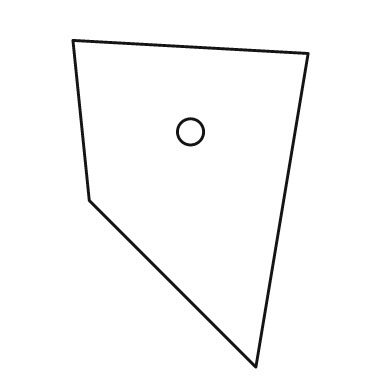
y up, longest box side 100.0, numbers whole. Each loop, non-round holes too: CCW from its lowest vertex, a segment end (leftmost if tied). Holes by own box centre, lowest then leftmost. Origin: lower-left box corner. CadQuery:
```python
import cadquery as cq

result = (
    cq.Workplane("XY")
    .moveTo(56.0, 0.0)
    .lineTo(72.0, 96.0)
    .lineTo(0.0, 100.0)
    .lineTo(5.0, 51.0)
    .close()
    .moveTo(36.0, 72.0)
    .circle(4.0)
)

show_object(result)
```